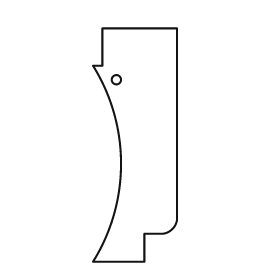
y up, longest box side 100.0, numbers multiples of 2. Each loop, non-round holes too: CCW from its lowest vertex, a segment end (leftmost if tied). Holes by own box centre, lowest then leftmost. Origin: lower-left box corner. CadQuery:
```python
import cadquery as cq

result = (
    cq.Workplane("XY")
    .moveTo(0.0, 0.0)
    .lineTo(22.0, 0.0)
    .lineTo(22.0, 12.0)
    .lineTo(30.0, 12.0)
    .threePointArc((34.0, 14.0), (36.0, 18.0))
    .lineTo(36.0, 100.0)
    .lineTo(4.0, 100.0)
    .lineTo(4.0, 84.0)
    .lineTo(0.0, 84.0)
    .threePointArc((12.0, 42.0), (0.0, 0.0))
    .close()
    .moveTo(10.0, 78.0)
    .circle(2.0)
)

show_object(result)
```